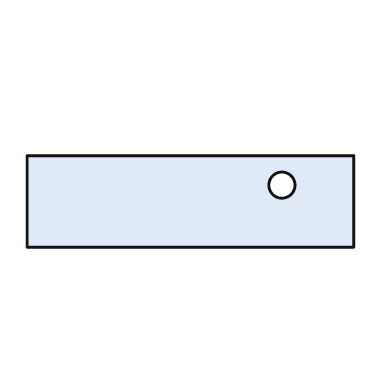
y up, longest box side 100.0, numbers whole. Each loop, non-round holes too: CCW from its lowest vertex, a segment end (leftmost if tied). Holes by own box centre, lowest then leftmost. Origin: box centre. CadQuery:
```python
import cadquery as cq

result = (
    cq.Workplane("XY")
    .moveTo(-50.0, -14.0)
    .lineTo(50.0, -14.0)
    .lineTo(50.0, 14.0)
    .lineTo(-50.0, 14.0)
    .close()
    .moveTo(28.0, 5.0)
    .circle(4.0)
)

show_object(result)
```